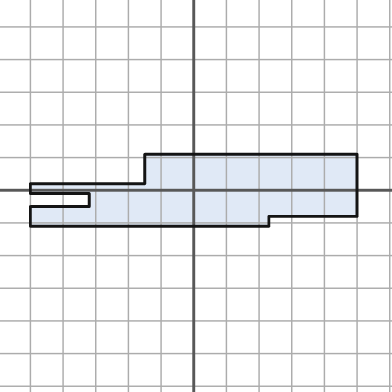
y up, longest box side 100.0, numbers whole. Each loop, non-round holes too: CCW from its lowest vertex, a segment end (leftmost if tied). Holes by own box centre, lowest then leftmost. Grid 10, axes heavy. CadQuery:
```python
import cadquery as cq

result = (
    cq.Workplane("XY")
    .moveTo(-50.0, -11.0)
    .lineTo(23.0, -11.0)
    .lineTo(23.0, -8.0)
    .lineTo(50.0, -8.0)
    .lineTo(50.0, 11.0)
    .lineTo(-15.0, 11.0)
    .lineTo(-15.0, 2.0)
    .lineTo(-50.0, 2.0)
    .lineTo(-50.0, -1.0)
    .lineTo(-32.0, -1.0)
    .lineTo(-32.0, -5.0)
    .lineTo(-50.0, -5.0)
    .close()
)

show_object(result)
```